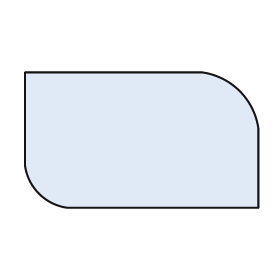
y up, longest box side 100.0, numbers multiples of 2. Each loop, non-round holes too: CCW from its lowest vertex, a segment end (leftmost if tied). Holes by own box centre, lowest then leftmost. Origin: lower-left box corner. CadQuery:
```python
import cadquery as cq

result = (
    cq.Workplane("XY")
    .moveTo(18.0, 0.0)
    .lineTo(100.0, 0.0)
    .lineTo(100.0, 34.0)
    .threePointArc((92.0, 50.0), (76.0, 58.0))
    .lineTo(0.0, 58.0)
    .lineTo(0.0, 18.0)
    .threePointArc((6.0, 6.0), (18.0, 0.0))
    .close()
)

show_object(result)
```